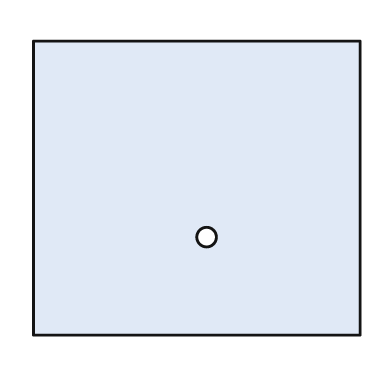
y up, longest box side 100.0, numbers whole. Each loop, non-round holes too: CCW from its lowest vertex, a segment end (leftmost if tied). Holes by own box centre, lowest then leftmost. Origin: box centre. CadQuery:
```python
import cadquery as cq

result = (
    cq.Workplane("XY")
    .moveTo(-50.0, -45.0)
    .lineTo(50.0, -45.0)
    .lineTo(50.0, 45.0)
    .lineTo(-50.0, 45.0)
    .close()
    .moveTo(3.0, -15.0)
    .circle(3.0)
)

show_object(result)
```